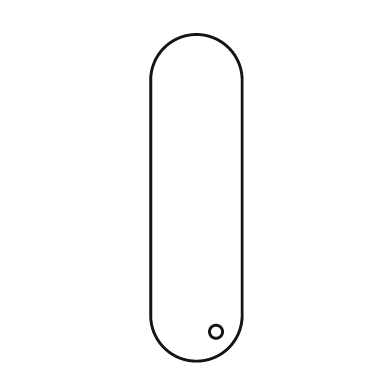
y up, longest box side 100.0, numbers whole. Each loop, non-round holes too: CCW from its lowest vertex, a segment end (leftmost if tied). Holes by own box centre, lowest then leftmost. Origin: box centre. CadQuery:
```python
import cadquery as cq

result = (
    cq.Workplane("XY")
    .moveTo(-14.0, -36.0)
    .threePointArc((0.0, -50.0), (14.0, -36.0))
    .lineTo(14.0, 36.0)
    .threePointArc((0.0, 50.0), (-14.0, 36.0))
    .close()
    .moveTo(6.0, -41.0)
    .circle(2.0)
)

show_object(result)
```